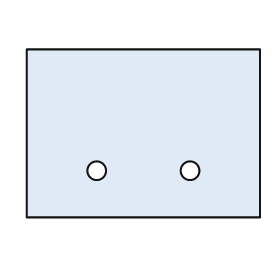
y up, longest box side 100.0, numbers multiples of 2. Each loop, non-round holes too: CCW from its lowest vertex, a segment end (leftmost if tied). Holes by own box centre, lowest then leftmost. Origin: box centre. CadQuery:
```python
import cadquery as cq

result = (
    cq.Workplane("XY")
    .moveTo(-50.0, -36.0)
    .lineTo(50.0, -36.0)
    .lineTo(50.0, 36.0)
    .lineTo(-50.0, 36.0)
    .close()
    .moveTo(-20.0, -16.0)
    .circle(4.0)
    .moveTo(20.0, -16.0)
    .circle(4.0)
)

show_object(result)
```